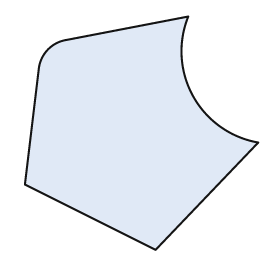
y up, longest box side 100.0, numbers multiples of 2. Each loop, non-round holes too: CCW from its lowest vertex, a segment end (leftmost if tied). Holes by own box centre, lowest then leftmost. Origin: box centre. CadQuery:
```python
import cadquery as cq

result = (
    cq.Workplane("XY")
    .moveTo(6.0, -50.0)
    .lineTo(50.0, -4.0)
    .threePointArc((22.0, 16.0), (20.0, 50.0))
    .lineTo(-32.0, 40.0)
    .threePointArc((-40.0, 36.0), (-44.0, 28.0))
    .lineTo(-50.0, -22.0)
    .close()
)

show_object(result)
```